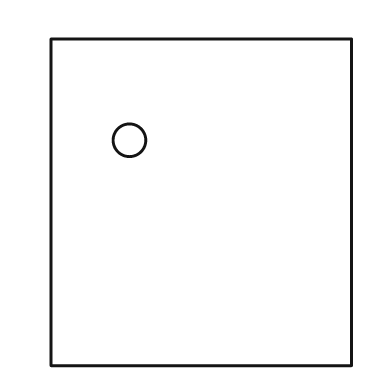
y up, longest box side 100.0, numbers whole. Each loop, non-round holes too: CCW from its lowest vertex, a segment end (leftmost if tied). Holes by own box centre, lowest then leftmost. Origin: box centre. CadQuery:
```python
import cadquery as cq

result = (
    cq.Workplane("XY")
    .moveTo(-46.0, -50.0)
    .lineTo(46.0, -50.0)
    .lineTo(46.0, 50.0)
    .lineTo(-46.0, 50.0)
    .close()
    .moveTo(-22.0, 19.0)
    .circle(5.0)
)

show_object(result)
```